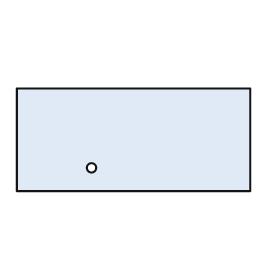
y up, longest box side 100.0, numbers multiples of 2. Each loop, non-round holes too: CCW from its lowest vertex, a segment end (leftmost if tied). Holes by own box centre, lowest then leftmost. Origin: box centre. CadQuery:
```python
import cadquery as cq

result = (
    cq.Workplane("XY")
    .moveTo(-50.0, -22.0)
    .lineTo(50.0, -22.0)
    .lineTo(50.0, 22.0)
    .lineTo(-50.0, 22.0)
    .close()
    .moveTo(-18.0, -12.0)
    .circle(2.0)
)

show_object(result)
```